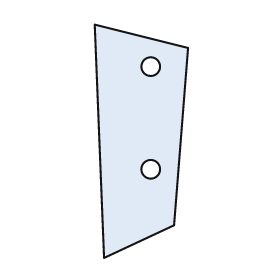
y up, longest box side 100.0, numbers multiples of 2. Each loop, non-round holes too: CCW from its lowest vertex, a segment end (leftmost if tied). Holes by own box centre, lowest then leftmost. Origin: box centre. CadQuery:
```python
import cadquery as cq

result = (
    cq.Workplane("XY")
    .moveTo(-16.0, -50.0)
    .lineTo(14.0, -36.0)
    .lineTo(20.0, 40.0)
    .lineTo(-20.0, 50.0)
    .close()
    .moveTo(4.0, -12.0)
    .circle(4.0)
    .moveTo(4.0, 32.0)
    .circle(4.0)
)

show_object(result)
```